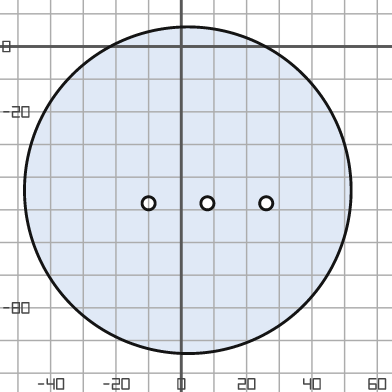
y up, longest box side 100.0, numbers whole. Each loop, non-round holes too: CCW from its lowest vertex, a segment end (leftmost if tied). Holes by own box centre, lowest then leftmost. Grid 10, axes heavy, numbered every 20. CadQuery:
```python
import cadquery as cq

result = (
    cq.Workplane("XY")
    .moveTo(2.0, -44.0)
    .circle(50.0)
    .moveTo(-10.0, -48.0)
    .circle(2.0)
    .moveTo(8.0, -48.0)
    .circle(2.0)
    .moveTo(26.0, -48.0)
    .circle(2.0)
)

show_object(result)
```